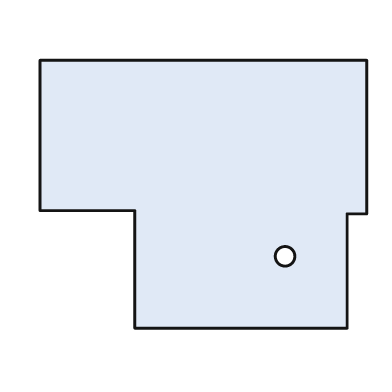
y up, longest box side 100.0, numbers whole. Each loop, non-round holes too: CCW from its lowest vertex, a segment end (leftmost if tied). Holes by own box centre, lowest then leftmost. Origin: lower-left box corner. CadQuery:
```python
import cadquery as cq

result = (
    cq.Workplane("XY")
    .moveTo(29.0, 0.0)
    .lineTo(94.0, 0.0)
    .lineTo(94.0, 35.0)
    .lineTo(100.0, 35.0)
    .lineTo(100.0, 82.0)
    .lineTo(0.0, 82.0)
    .lineTo(0.0, 36.0)
    .lineTo(29.0, 36.0)
    .close()
    .moveTo(75.0, 22.0)
    .circle(3.0)
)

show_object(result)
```